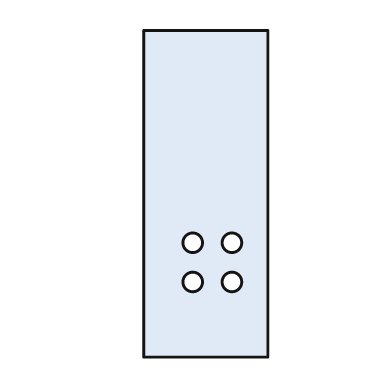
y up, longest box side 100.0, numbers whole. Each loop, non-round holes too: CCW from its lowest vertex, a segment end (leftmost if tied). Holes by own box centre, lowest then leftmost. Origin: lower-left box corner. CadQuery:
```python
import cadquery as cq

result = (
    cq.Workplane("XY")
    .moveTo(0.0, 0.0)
    .lineTo(38.0, 0.0)
    .lineTo(38.0, 100.0)
    .lineTo(0.0, 100.0)
    .close()
    .moveTo(15.0, 23.0)
    .circle(3.0)
    .moveTo(27.0, 23.0)
    .circle(3.0)
    .moveTo(15.0, 35.0)
    .circle(3.0)
    .moveTo(27.0, 35.0)
    .circle(3.0)
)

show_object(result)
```